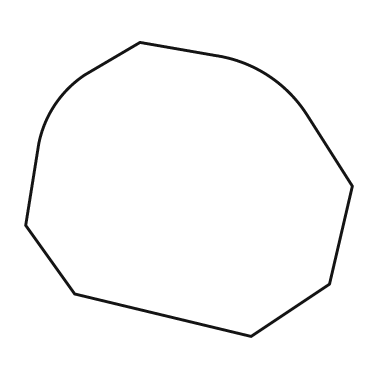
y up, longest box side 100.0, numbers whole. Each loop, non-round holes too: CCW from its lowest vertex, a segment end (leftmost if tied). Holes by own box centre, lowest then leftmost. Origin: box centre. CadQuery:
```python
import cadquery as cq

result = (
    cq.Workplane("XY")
    .moveTo(19.0, -45.0)
    .lineTo(43.0, -29.0)
    .lineTo(50.0, 1.0)
    .lineTo(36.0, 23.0)
    .threePointArc((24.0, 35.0), (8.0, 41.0))
    .lineTo(-15.0, 45.0)
    .lineTo(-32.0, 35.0)
    .threePointArc((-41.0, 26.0), (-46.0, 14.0))
    .lineTo(-50.0, -11.0)
    .lineTo(-35.0, -32.0)
    .close()
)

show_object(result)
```